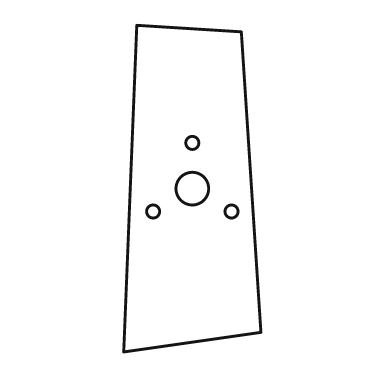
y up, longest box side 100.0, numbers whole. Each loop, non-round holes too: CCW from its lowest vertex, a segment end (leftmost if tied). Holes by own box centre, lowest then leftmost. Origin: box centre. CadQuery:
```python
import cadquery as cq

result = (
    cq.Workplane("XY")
    .moveTo(-21.0, -50.0)
    .lineTo(21.0, -44.0)
    .lineTo(15.0, 48.0)
    .lineTo(-17.0, 50.0)
    .close()
    .moveTo(-12.0, -7.0)
    .circle(2.0)
    .moveTo(12.0, -7.0)
    .circle(2.0)
    .moveTo(0.0, 0.0)
    .circle(5.0)
    .moveTo(0.0, 14.0)
    .circle(2.0)
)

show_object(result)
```